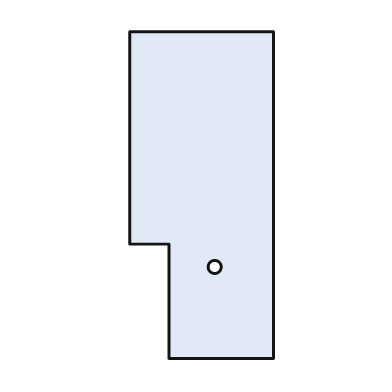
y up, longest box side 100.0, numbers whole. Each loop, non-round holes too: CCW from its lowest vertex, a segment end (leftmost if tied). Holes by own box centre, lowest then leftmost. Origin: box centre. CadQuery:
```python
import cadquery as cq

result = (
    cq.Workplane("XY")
    .moveTo(-10.0, -50.0)
    .lineTo(22.0, -50.0)
    .lineTo(22.0, 50.0)
    .lineTo(-22.0, 50.0)
    .lineTo(-22.0, -15.0)
    .lineTo(-10.0, -15.0)
    .close()
    .moveTo(4.0, -22.0)
    .circle(2.0)
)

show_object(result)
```